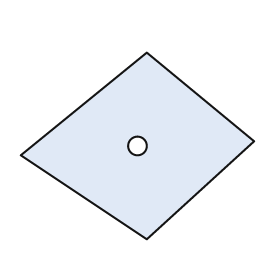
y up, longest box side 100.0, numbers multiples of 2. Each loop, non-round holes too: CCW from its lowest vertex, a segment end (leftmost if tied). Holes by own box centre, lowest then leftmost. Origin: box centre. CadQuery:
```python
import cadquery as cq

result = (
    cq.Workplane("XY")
    .moveTo(4.0, -40.0)
    .lineTo(50.0, 2.0)
    .lineTo(4.0, 40.0)
    .lineTo(-50.0, -4.0)
    .close()
    .moveTo(0.0, 0.0)
    .circle(4.0)
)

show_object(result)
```